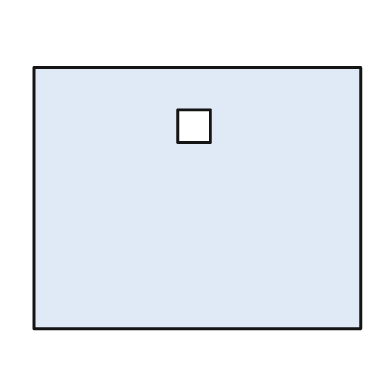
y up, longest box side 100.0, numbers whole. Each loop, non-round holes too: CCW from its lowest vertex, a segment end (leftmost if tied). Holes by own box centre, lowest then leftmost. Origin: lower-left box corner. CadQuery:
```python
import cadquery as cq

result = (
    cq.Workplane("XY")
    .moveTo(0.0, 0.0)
    .lineTo(100.0, 0.0)
    .lineTo(100.0, 80.0)
    .lineTo(0.0, 80.0)
    .close()
    .moveTo(44.0, 57.0)
    .lineTo(54.0, 57.0)
    .lineTo(54.0, 67.0)
    .lineTo(44.0, 67.0)
    .close()
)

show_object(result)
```